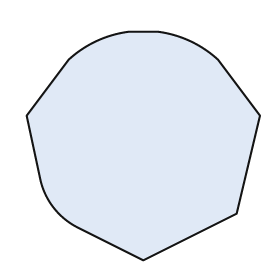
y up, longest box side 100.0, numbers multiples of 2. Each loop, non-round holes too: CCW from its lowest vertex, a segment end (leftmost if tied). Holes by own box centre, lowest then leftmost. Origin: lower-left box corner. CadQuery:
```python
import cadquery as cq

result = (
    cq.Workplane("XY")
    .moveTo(50.0, 0.0)
    .lineTo(90.0, 20.0)
    .lineTo(100.0, 62.0)
    .lineTo(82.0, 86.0)
    .threePointArc((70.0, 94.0), (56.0, 98.0))
    .lineTo(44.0, 98.0)
    .threePointArc((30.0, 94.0), (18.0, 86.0))
    .lineTo(0.0, 62.0)
    .lineTo(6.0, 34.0)
    .threePointArc((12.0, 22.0), (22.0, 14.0))
    .close()
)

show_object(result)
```